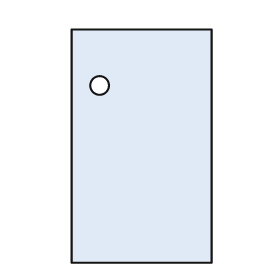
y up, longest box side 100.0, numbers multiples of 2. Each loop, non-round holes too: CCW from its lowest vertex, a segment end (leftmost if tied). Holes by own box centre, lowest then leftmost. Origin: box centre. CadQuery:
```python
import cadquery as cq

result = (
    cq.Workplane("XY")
    .moveTo(-30.0, -50.0)
    .lineTo(30.0, -50.0)
    .lineTo(30.0, 50.0)
    .lineTo(-30.0, 50.0)
    .close()
    .moveTo(-18.0, 26.0)
    .circle(4.0)
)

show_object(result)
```